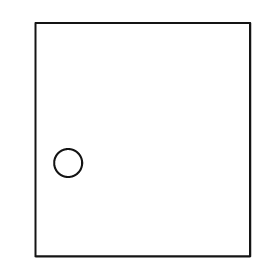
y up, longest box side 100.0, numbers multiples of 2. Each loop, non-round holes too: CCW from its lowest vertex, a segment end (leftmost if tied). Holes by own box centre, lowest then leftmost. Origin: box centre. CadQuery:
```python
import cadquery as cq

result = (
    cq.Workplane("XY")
    .moveTo(-46.0, -50.0)
    .lineTo(46.0, -50.0)
    .lineTo(46.0, 50.0)
    .lineTo(-46.0, 50.0)
    .close()
    .moveTo(-32.0, -10.0)
    .circle(6.0)
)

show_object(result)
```